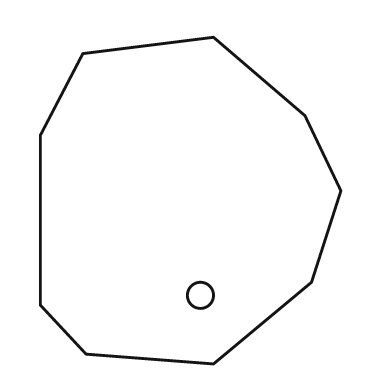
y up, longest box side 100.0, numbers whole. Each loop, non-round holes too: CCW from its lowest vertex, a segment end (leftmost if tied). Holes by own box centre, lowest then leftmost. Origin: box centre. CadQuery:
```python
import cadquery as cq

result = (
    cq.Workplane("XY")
    .moveTo(7.0, -50.0)
    .lineTo(37.0, -25.0)
    .lineTo(46.0, 3.0)
    .lineTo(35.0, 26.0)
    .lineTo(7.0, 50.0)
    .lineTo(-33.0, 45.0)
    .lineTo(-46.0, 20.0)
    .lineTo(-46.0, -32.0)
    .lineTo(-32.0, -47.0)
    .close()
    .moveTo(3.0, -29.0)
    .circle(4.0)
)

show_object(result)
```